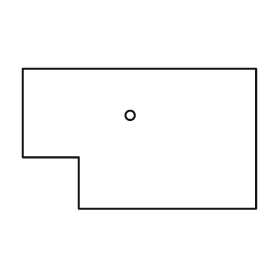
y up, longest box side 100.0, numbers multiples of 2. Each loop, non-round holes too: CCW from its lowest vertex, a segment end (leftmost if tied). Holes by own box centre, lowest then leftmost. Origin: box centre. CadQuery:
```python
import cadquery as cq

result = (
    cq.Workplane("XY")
    .moveTo(-26.0, -30.0)
    .lineTo(50.0, -30.0)
    .lineTo(50.0, 30.0)
    .lineTo(-50.0, 30.0)
    .lineTo(-50.0, -8.0)
    .lineTo(-26.0, -8.0)
    .close()
    .moveTo(-4.0, 10.0)
    .circle(2.0)
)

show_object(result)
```